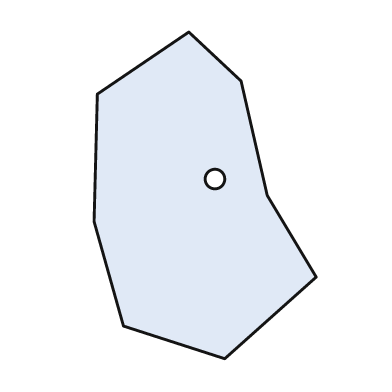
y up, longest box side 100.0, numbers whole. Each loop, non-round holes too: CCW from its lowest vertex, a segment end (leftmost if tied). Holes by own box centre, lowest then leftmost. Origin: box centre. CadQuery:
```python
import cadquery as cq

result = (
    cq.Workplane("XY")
    .moveTo(6.0, -50.0)
    .lineTo(34.0, -25.0)
    .lineTo(19.0, 0.0)
    .lineTo(11.0, 35.0)
    .lineTo(-5.0, 50.0)
    .lineTo(-33.0, 31.0)
    .lineTo(-34.0, -8.0)
    .lineTo(-25.0, -40.0)
    .close()
    .moveTo(3.0, 5.0)
    .circle(3.0)
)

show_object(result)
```